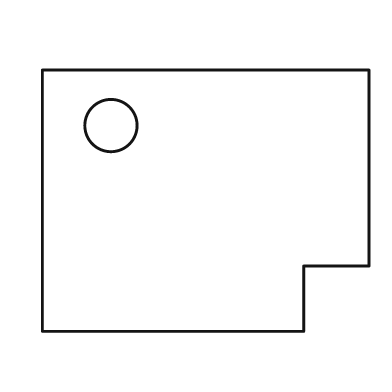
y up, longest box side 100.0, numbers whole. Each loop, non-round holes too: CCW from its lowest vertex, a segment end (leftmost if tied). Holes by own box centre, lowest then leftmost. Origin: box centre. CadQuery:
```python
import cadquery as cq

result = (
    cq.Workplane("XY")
    .moveTo(-50.0, -40.0)
    .lineTo(30.0, -40.0)
    .lineTo(30.0, -20.0)
    .lineTo(50.0, -20.0)
    .lineTo(50.0, 40.0)
    .lineTo(-50.0, 40.0)
    .close()
    .moveTo(-29.0, 23.0)
    .circle(8.0)
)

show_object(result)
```